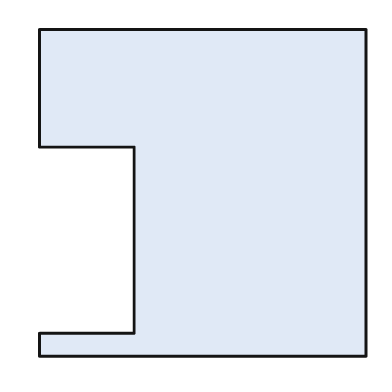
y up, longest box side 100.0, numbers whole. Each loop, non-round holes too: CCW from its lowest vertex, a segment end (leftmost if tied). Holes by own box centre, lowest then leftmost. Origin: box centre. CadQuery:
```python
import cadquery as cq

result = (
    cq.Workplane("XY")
    .moveTo(-50.0, -50.0)
    .lineTo(50.0, -50.0)
    .lineTo(50.0, 50.0)
    .lineTo(-50.0, 50.0)
    .lineTo(-50.0, 14.0)
    .lineTo(-21.0, 14.0)
    .lineTo(-21.0, -43.0)
    .lineTo(-50.0, -43.0)
    .close()
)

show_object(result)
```